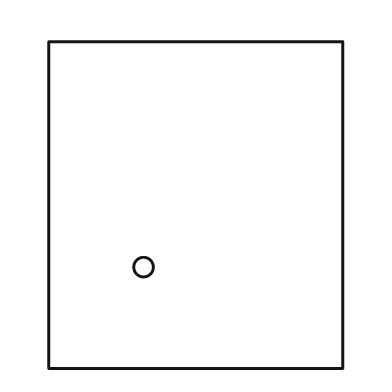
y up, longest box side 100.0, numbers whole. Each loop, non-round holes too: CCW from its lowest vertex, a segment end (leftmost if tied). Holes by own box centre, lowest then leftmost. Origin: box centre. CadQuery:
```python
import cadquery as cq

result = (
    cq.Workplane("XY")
    .moveTo(-45.0, -50.0)
    .lineTo(45.0, -50.0)
    .lineTo(45.0, 50.0)
    .lineTo(-45.0, 50.0)
    .close()
    .moveTo(-16.0, -19.0)
    .circle(3.0)
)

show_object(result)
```